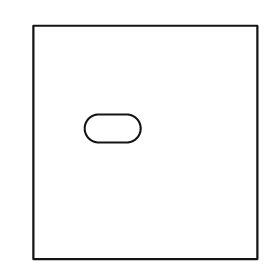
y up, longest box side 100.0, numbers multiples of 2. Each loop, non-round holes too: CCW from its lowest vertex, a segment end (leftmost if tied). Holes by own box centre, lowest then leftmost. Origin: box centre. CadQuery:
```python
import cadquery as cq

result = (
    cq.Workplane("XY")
    .moveTo(-48.0, -50.0)
    .lineTo(48.0, -50.0)
    .lineTo(48.0, 50.0)
    .lineTo(-48.0, 50.0)
    .close()
    .moveTo(-20.0, 0.0)
    .lineTo(-8.0, 0.0)
    .threePointArc((-2.0, 6.0), (-8.0, 12.0))
    .lineTo(-20.0, 12.0)
    .threePointArc((-26.0, 6.0), (-20.0, 0.0))
    .close()
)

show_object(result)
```